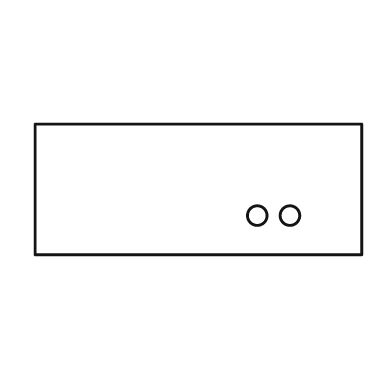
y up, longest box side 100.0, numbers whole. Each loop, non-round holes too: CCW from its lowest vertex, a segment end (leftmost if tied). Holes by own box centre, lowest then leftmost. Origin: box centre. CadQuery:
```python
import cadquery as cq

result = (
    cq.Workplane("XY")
    .moveTo(-50.0, -20.0)
    .lineTo(50.0, -20.0)
    .lineTo(50.0, 20.0)
    .lineTo(-50.0, 20.0)
    .close()
    .moveTo(18.0, -8.0)
    .circle(3.0)
    .moveTo(28.0, -8.0)
    .circle(3.0)
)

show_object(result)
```